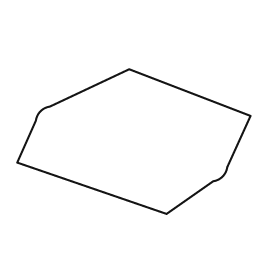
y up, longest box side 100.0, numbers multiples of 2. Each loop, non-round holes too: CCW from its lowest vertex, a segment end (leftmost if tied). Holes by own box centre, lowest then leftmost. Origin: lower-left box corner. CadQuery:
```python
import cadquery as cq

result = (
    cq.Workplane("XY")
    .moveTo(64.0, 0.0)
    .lineTo(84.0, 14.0)
    .threePointArc((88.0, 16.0), (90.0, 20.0))
    .lineTo(100.0, 42.0)
    .lineTo(48.0, 62.0)
    .lineTo(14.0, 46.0)
    .threePointArc((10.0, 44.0), (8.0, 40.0))
    .lineTo(0.0, 22.0)
    .close()
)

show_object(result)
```